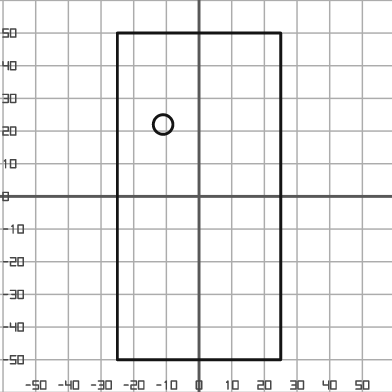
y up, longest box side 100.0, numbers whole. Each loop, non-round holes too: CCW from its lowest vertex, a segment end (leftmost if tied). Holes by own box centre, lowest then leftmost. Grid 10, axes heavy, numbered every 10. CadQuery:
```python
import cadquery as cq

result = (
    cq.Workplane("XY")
    .moveTo(-25.0, -50.0)
    .lineTo(25.0, -50.0)
    .lineTo(25.0, 50.0)
    .lineTo(-25.0, 50.0)
    .close()
    .moveTo(-11.0, 22.0)
    .circle(3.0)
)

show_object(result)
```